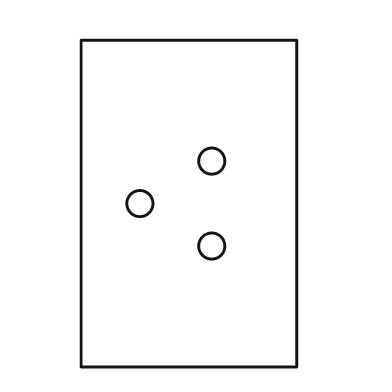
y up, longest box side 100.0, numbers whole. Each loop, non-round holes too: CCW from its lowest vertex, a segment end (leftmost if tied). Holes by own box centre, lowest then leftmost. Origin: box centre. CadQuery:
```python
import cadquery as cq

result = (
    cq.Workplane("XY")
    .moveTo(-33.0, -50.0)
    .lineTo(33.0, -50.0)
    .lineTo(33.0, 50.0)
    .lineTo(-33.0, 50.0)
    .close()
    .moveTo(7.0, -13.0)
    .circle(4.0)
    .moveTo(-15.0, 0.0)
    .circle(4.0)
    .moveTo(7.0, 13.0)
    .circle(4.0)
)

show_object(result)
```